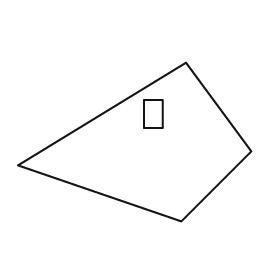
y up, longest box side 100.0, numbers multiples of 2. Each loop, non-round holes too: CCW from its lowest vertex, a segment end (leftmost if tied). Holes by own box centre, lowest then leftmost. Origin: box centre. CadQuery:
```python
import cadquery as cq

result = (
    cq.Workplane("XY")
    .moveTo(20.0, -34.0)
    .lineTo(50.0, -4.0)
    .lineTo(22.0, 34.0)
    .lineTo(-50.0, -10.0)
    .close()
    .moveTo(4.0, 6.0)
    .lineTo(12.0, 6.0)
    .lineTo(12.0, 18.0)
    .lineTo(4.0, 18.0)
    .close()
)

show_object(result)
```